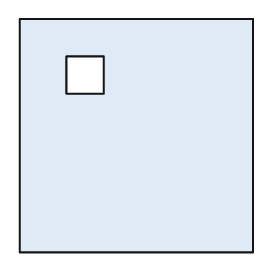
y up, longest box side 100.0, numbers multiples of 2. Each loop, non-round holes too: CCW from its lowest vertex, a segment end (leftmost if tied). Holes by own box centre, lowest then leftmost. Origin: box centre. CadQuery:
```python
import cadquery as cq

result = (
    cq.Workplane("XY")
    .moveTo(-50.0, -50.0)
    .lineTo(50.0, -50.0)
    .lineTo(50.0, 50.0)
    .lineTo(-50.0, 50.0)
    .close()
    .moveTo(-30.0, 18.0)
    .lineTo(-14.0, 18.0)
    .lineTo(-14.0, 34.0)
    .lineTo(-30.0, 34.0)
    .close()
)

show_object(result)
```